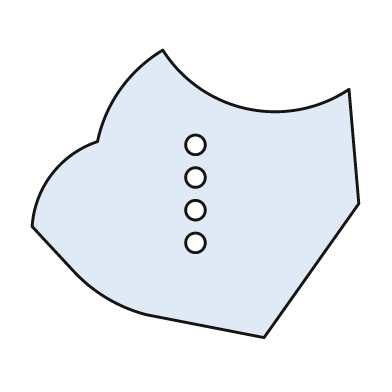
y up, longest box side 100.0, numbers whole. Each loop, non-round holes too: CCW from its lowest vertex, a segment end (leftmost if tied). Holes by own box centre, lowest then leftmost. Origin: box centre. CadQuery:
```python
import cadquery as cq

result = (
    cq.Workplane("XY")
    .moveTo(21.0, -44.0)
    .lineTo(50.0, -3.0)
    .lineTo(47.0, 32.0)
    .threePointArc((16.0, 26.0), (-10.0, 44.0))
    .threePointArc((-23.0, 32.0), (-30.0, 16.0))
    .threePointArc((-44.0, 6.0), (-50.0, -10.0))
    .lineTo(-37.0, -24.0)
    .threePointArc((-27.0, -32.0), (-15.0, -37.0))
    .close()
    .moveTo(0.0, -15.0)
    .circle(3.0)
    .moveTo(0.0, -5.0)
    .circle(3.0)
    .moveTo(0.0, 5.0)
    .circle(3.0)
    .moveTo(0.0, 15.0)
    .circle(3.0)
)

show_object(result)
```